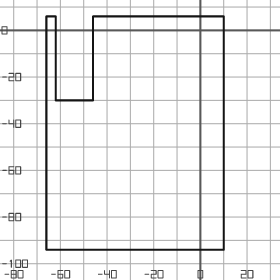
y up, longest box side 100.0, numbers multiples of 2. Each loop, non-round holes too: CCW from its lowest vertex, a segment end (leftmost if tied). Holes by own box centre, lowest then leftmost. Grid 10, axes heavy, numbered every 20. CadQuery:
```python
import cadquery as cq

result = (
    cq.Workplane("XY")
    .moveTo(-66.0, -94.0)
    .lineTo(10.0, -94.0)
    .lineTo(10.0, 6.0)
    .lineTo(-46.0, 6.0)
    .lineTo(-46.0, -30.0)
    .lineTo(-62.0, -30.0)
    .lineTo(-62.0, 6.0)
    .lineTo(-66.0, 6.0)
    .close()
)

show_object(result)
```